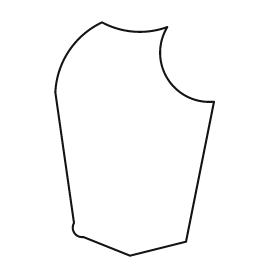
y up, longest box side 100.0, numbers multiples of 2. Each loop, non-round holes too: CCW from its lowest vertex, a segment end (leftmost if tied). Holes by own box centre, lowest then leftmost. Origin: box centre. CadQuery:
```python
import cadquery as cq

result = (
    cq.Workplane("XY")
    .moveTo(-2.0, -50.0)
    .lineTo(22.0, -44.0)
    .lineTo(34.0, 16.0)
    .threePointArc((14.0, 26.0), (14.0, 48.0))
    .threePointArc((0.0, 46.0), (-14.0, 50.0))
    .threePointArc((-28.0, 38.0), (-34.0, 20.0))
    .lineTo(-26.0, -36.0)
    .threePointArc((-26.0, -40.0), (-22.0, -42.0))
    .close()
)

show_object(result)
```